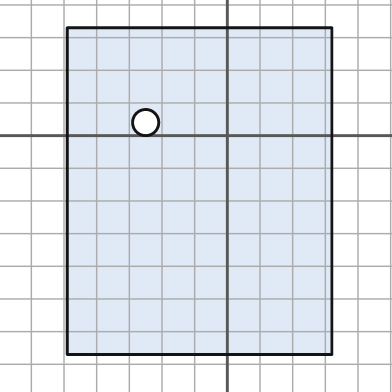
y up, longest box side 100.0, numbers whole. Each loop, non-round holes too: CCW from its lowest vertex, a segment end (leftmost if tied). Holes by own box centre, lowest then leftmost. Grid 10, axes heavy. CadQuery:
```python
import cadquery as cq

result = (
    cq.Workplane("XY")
    .moveTo(-49.0, -67.0)
    .lineTo(32.0, -67.0)
    .lineTo(32.0, 33.0)
    .lineTo(-49.0, 33.0)
    .close()
    .moveTo(-25.0, 4.0)
    .circle(4.0)
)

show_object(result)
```